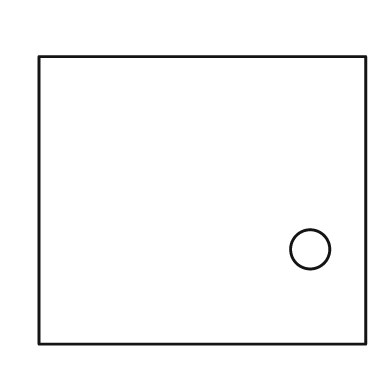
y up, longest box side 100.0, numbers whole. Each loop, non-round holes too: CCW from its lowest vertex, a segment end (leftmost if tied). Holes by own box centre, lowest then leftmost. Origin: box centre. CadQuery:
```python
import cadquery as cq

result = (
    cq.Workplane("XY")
    .moveTo(-50.0, -44.0)
    .lineTo(50.0, -44.0)
    .lineTo(50.0, 44.0)
    .lineTo(-50.0, 44.0)
    .close()
    .moveTo(33.0, -15.0)
    .circle(6.0)
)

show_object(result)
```